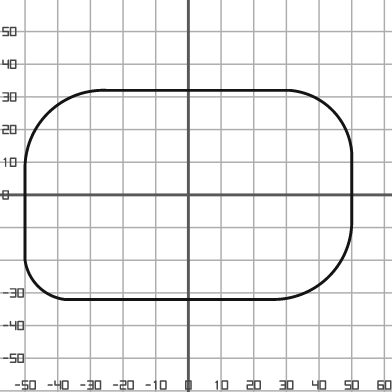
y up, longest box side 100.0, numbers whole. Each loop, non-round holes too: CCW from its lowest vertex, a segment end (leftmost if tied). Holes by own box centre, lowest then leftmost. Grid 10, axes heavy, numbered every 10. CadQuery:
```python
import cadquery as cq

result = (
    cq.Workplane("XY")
    .moveTo(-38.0, -32.0)
    .lineTo(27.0, -32.0)
    .threePointArc((43.0, -25.0), (50.0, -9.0))
    .lineTo(50.0, 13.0)
    .threePointArc((44.0, 26.0), (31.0, 32.0))
    .lineTo(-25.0, 32.0)
    .threePointArc((-43.0, 25.0), (-50.0, 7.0))
    .lineTo(-50.0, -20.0)
    .threePointArc((-46.0, -28.0), (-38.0, -32.0))
    .close()
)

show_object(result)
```